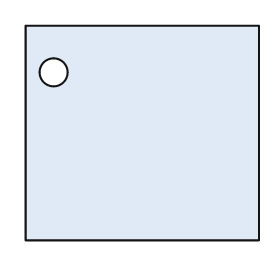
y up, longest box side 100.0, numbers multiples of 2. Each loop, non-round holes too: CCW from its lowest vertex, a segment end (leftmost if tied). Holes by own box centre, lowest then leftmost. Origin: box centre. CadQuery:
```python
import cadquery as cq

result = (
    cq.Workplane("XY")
    .moveTo(-50.0, -46.0)
    .lineTo(50.0, -46.0)
    .lineTo(50.0, 46.0)
    .lineTo(-50.0, 46.0)
    .close()
    .moveTo(-38.0, 26.0)
    .circle(6.0)
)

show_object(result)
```